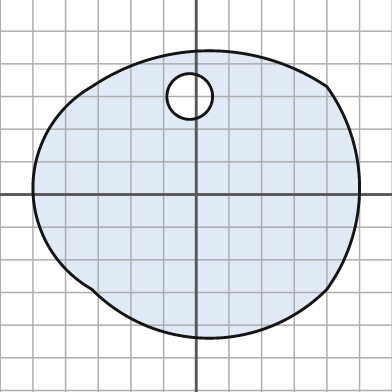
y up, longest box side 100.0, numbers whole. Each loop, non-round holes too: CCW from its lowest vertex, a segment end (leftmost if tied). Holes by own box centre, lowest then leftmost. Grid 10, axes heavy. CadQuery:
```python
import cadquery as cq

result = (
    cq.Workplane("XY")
    .moveTo(-32.0, -29.0)
    .threePointArc((4.0, -44.0), (40.0, -29.0))
    .threePointArc((50.0, 2.0), (40.0, 33.0))
    .threePointArc((4.0, 44.0), (-32.0, 33.0))
    .threePointArc((-50.0, 2.0), (-32.0, -29.0))
    .close()
    .moveTo(-2.0, 30.0)
    .circle(7.0)
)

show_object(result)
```